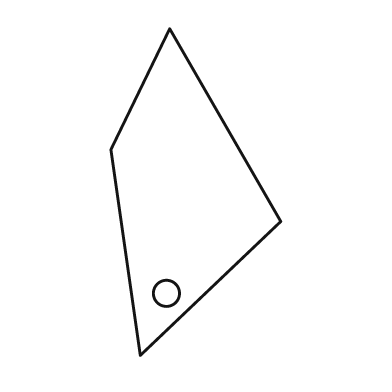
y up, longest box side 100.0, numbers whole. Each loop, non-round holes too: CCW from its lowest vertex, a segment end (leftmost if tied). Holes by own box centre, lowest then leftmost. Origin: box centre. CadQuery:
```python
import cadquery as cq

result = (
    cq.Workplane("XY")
    .moveTo(-17.0, -50.0)
    .lineTo(26.0, -9.0)
    .lineTo(-8.0, 50.0)
    .lineTo(-26.0, 13.0)
    .close()
    .moveTo(-9.0, -31.0)
    .circle(4.0)
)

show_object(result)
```